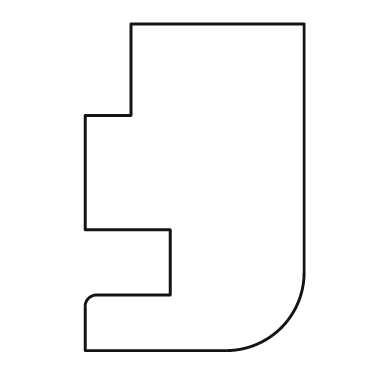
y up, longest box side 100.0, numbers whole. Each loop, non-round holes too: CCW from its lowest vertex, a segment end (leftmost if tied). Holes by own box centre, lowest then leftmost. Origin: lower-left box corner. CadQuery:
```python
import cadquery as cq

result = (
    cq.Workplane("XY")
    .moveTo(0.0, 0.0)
    .lineTo(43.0, 0.0)
    .threePointArc((60.0, 7.0), (67.0, 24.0))
    .lineTo(67.0, 100.0)
    .lineTo(14.0, 100.0)
    .lineTo(14.0, 72.0)
    .lineTo(0.0, 72.0)
    .lineTo(0.0, 37.0)
    .lineTo(26.0, 37.0)
    .lineTo(26.0, 17.0)
    .lineTo(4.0, 17.0)
    .threePointArc((1.0, 16.0), (0.0, 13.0))
    .close()
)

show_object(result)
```